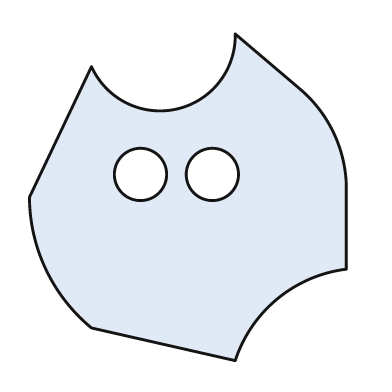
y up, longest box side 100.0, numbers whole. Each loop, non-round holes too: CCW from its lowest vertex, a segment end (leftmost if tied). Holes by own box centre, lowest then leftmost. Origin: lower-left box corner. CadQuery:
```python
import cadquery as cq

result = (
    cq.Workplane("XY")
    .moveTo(63.0, 0.0)
    .threePointArc((76.0, 19.0), (97.0, 28.0))
    .lineTo(97.0, 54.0)
    .threePointArc((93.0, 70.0), (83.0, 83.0))
    .lineTo(63.0, 100.0)
    .threePointArc((45.0, 77.0), (19.0, 90.0))
    .lineTo(0.0, 50.0)
    .threePointArc((5.0, 28.0), (19.0, 10.0))
    .close()
    .moveTo(34.0, 57.0)
    .circle(8.0)
    .moveTo(56.0, 57.0)
    .circle(8.0)
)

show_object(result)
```